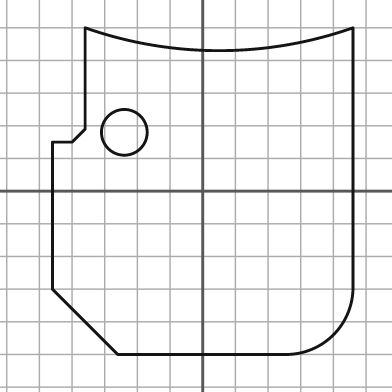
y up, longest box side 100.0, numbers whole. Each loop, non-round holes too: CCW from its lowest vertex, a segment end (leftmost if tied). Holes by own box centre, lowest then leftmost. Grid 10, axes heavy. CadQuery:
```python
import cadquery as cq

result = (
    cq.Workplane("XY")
    .moveTo(-26.0, -50.0)
    .lineTo(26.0, -50.0)
    .threePointArc((40.0, -44.0), (46.0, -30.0))
    .lineTo(46.0, 50.0)
    .threePointArc((5.0, 43.0), (-36.0, 50.0))
    .lineTo(-36.0, 19.0)
    .lineTo(-40.0, 15.0)
    .lineTo(-46.0, 15.0)
    .lineTo(-46.0, -30.0)
    .close()
    .moveTo(-24.0, 18.0)
    .circle(7.0)
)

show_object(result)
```